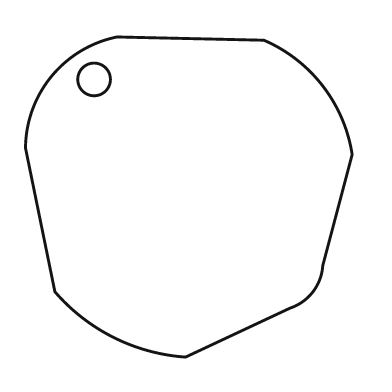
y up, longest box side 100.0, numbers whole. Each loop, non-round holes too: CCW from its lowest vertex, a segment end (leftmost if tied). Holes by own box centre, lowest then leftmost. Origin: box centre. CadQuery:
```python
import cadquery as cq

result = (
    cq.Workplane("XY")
    .moveTo(-1.0, -49.0)
    .lineTo(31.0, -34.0)
    .threePointArc((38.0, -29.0), (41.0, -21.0))
    .lineTo(50.0, 13.0)
    .threePointArc((41.0, 34.0), (23.0, 48.0))
    .lineTo(-22.0, 49.0)
    .threePointArc((-42.0, 37.0), (-50.0, 15.0))
    .lineTo(-41.0, -29.0)
    .threePointArc((-23.0, -43.0), (-1.0, -49.0))
    .close()
    .moveTo(-29.0, 36.0)
    .circle(5.0)
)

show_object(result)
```